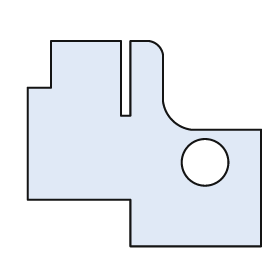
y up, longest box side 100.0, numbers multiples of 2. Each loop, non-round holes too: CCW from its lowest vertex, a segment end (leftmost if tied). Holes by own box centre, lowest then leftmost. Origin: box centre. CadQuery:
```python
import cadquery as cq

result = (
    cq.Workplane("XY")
    .moveTo(-6.0, -44.0)
    .lineTo(50.0, -44.0)
    .lineTo(50.0, 6.0)
    .lineTo(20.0, 6.0)
    .threePointArc((12.0, 10.0), (8.0, 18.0))
    .lineTo(8.0, 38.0)
    .threePointArc((6.0, 42.0), (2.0, 44.0))
    .lineTo(-6.0, 44.0)
    .lineTo(-6.0, 12.0)
    .lineTo(-10.0, 12.0)
    .lineTo(-10.0, 44.0)
    .lineTo(-40.0, 44.0)
    .lineTo(-40.0, 24.0)
    .lineTo(-50.0, 24.0)
    .lineTo(-50.0, -24.0)
    .lineTo(-6.0, -24.0)
    .close()
    .moveTo(26.0, -8.0)
    .circle(10.0)
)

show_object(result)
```